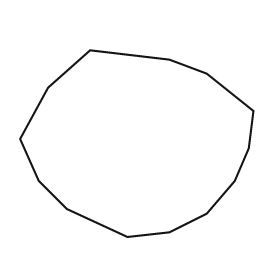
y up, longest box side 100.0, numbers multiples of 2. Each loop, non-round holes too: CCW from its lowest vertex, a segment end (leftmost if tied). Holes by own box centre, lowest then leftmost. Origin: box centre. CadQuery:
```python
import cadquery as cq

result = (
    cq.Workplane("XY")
    .moveTo(-4.0, -40.0)
    .lineTo(14.0, -38.0)
    .lineTo(30.0, -30.0)
    .lineTo(42.0, -16.0)
    .lineTo(48.0, -2.0)
    .lineTo(50.0, 14.0)
    .lineTo(30.0, 30.0)
    .lineTo(14.0, 36.0)
    .lineTo(-20.0, 40.0)
    .lineTo(-38.0, 24.0)
    .lineTo(-50.0, 2.0)
    .lineTo(-42.0, -16.0)
    .lineTo(-30.0, -28.0)
    .close()
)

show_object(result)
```